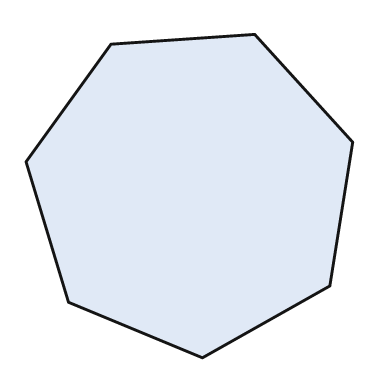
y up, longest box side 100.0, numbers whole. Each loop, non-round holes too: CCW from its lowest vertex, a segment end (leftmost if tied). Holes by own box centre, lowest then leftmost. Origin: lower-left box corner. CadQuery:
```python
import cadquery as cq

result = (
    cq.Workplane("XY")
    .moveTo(54.0, 0.0)
    .lineTo(93.0, 22.0)
    .lineTo(100.0, 66.0)
    .lineTo(70.0, 99.0)
    .lineTo(26.0, 96.0)
    .lineTo(0.0, 60.0)
    .lineTo(13.0, 17.0)
    .close()
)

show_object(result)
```